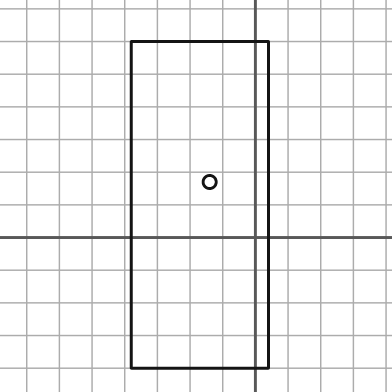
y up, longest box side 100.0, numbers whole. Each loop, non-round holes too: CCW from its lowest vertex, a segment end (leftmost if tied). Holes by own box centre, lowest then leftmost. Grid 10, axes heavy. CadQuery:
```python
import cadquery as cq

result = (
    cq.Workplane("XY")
    .moveTo(-38.0, -40.0)
    .lineTo(4.0, -40.0)
    .lineTo(4.0, 60.0)
    .lineTo(-38.0, 60.0)
    .close()
    .moveTo(-14.0, 17.0)
    .circle(2.0)
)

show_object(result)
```